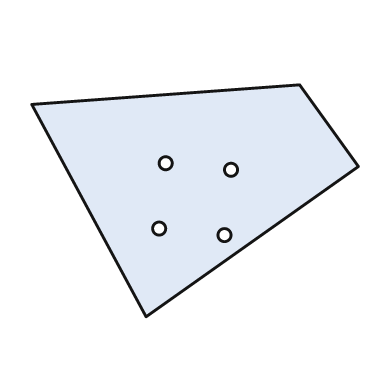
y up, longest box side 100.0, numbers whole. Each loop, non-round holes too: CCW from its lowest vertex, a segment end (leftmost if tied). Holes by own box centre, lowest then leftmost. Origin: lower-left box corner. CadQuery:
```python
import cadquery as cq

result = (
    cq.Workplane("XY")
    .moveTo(35.0, 0.0)
    .lineTo(100.0, 46.0)
    .lineTo(82.0, 71.0)
    .lineTo(0.0, 65.0)
    .close()
    .moveTo(59.0, 25.0)
    .circle(2.0)
    .moveTo(39.0, 27.0)
    .circle(2.0)
    .moveTo(61.0, 45.0)
    .circle(2.0)
    .moveTo(41.0, 47.0)
    .circle(2.0)
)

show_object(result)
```